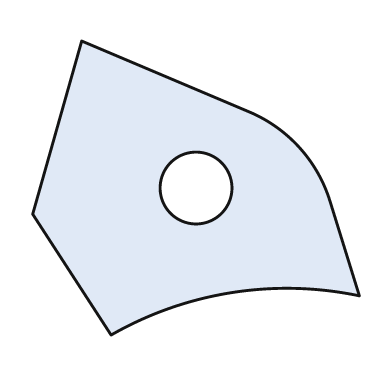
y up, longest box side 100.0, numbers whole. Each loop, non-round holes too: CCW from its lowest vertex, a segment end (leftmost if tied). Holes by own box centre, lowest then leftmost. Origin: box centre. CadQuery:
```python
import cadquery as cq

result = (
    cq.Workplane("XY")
    .moveTo(-26.0, -45.0)
    .threePointArc((11.0, -32.0), (50.0, -33.0))
    .lineTo(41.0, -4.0)
    .threePointArc((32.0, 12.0), (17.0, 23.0))
    .lineTo(-35.0, 45.0)
    .lineTo(-50.0, -8.0)
    .close()
    .moveTo(0.0, 0.0)
    .circle(11.0)
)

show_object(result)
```